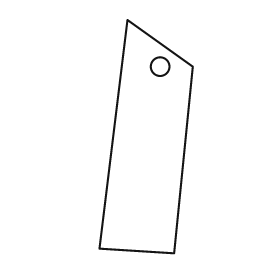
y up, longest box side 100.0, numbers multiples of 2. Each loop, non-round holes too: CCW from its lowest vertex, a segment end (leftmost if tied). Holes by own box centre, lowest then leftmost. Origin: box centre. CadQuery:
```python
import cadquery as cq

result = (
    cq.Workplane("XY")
    .moveTo(12.0, -50.0)
    .lineTo(20.0, 30.0)
    .lineTo(-8.0, 50.0)
    .lineTo(-20.0, -48.0)
    .close()
    .moveTo(6.0, 30.0)
    .circle(4.0)
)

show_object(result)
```